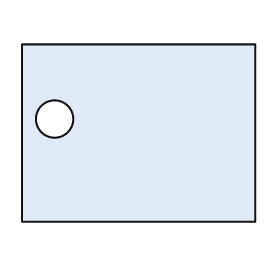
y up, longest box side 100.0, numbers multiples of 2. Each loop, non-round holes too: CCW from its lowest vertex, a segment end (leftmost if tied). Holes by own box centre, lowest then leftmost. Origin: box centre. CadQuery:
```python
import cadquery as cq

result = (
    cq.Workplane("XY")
    .moveTo(-50.0, -38.0)
    .lineTo(50.0, -38.0)
    .lineTo(50.0, 38.0)
    .lineTo(-50.0, 38.0)
    .close()
    .moveTo(-36.0, 6.0)
    .circle(8.0)
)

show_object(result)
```